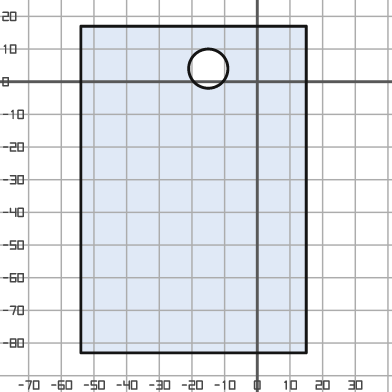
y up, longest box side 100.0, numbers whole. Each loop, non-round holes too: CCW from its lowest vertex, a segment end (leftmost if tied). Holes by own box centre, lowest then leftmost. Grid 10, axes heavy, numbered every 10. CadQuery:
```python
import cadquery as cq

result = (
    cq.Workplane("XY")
    .moveTo(-54.0, -83.0)
    .lineTo(15.0, -83.0)
    .lineTo(15.0, 17.0)
    .lineTo(-54.0, 17.0)
    .close()
    .moveTo(-15.0, 4.0)
    .circle(6.0)
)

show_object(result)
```